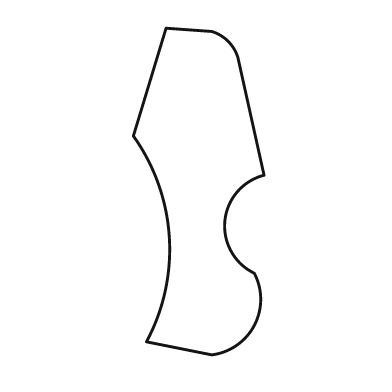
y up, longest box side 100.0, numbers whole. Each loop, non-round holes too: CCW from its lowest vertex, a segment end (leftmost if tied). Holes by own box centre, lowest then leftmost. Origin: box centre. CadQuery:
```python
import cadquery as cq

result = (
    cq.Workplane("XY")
    .moveTo(4.0, -50.0)
    .threePointArc((17.0, -41.0), (17.0, -25.0))
    .threePointArc((8.0, -9.0), (20.0, 5.0))
    .lineTo(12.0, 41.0)
    .threePointArc((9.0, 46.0), (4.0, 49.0))
    .lineTo(-10.0, 50.0)
    .lineTo(-20.0, 17.0)
    .threePointArc((-9.0, -14.0), (-16.0, -46.0))
    .close()
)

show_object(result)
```